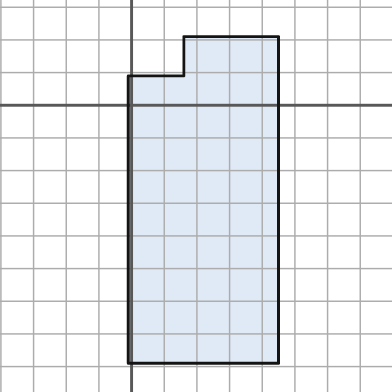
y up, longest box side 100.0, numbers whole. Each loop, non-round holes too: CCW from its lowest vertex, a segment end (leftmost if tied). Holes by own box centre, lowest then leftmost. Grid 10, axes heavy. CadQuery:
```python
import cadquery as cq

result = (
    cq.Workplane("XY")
    .moveTo(-1.0, -79.0)
    .lineTo(45.0, -79.0)
    .lineTo(45.0, 21.0)
    .lineTo(16.0, 21.0)
    .lineTo(16.0, 9.0)
    .lineTo(-1.0, 9.0)
    .close()
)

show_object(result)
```